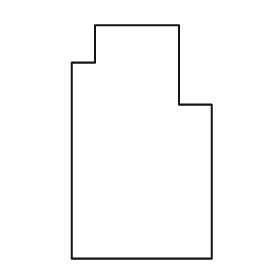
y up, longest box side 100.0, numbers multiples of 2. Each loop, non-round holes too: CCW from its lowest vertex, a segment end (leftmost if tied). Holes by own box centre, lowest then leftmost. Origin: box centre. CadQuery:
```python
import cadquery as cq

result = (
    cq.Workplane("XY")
    .moveTo(-30.0, -50.0)
    .lineTo(30.0, -50.0)
    .lineTo(30.0, 16.0)
    .lineTo(16.0, 16.0)
    .lineTo(16.0, 50.0)
    .lineTo(-20.0, 50.0)
    .lineTo(-20.0, 34.0)
    .lineTo(-30.0, 34.0)
    .close()
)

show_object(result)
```